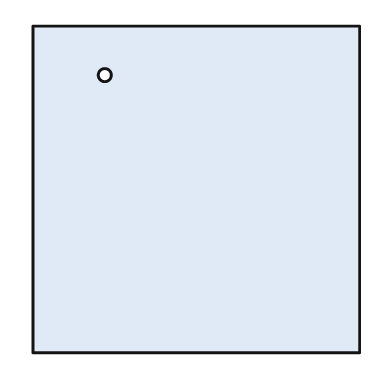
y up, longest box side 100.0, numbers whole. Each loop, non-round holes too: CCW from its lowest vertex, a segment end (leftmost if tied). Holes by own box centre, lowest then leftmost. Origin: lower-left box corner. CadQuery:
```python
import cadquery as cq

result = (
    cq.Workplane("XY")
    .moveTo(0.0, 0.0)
    .lineTo(100.0, 0.0)
    .lineTo(100.0, 100.0)
    .lineTo(0.0, 100.0)
    .close()
    .moveTo(22.0, 85.0)
    .circle(2.0)
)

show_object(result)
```